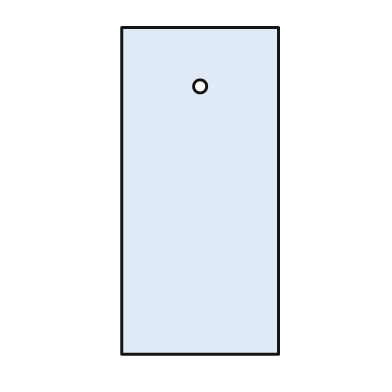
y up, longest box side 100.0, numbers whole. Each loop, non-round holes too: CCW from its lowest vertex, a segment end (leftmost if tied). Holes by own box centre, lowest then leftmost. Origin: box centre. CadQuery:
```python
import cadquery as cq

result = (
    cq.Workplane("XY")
    .moveTo(-24.0, -50.0)
    .lineTo(24.0, -50.0)
    .lineTo(24.0, 50.0)
    .lineTo(-24.0, 50.0)
    .close()
    .moveTo(0.0, 32.0)
    .circle(2.0)
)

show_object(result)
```